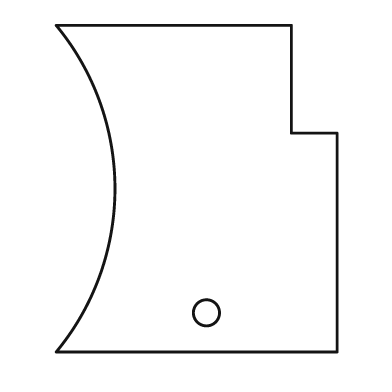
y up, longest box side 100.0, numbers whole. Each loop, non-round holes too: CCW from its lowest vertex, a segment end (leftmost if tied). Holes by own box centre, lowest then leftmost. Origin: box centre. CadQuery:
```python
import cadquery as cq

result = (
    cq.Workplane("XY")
    .moveTo(-43.0, -50.0)
    .lineTo(43.0, -50.0)
    .lineTo(43.0, 17.0)
    .lineTo(29.0, 17.0)
    .lineTo(29.0, 50.0)
    .lineTo(-43.0, 50.0)
    .threePointArc((-25.0, 0.0), (-43.0, -50.0))
    .close()
    .moveTo(3.0, -38.0)
    .circle(4.0)
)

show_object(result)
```